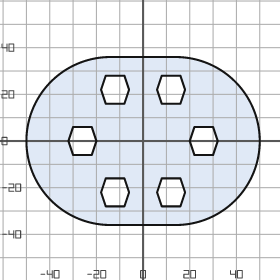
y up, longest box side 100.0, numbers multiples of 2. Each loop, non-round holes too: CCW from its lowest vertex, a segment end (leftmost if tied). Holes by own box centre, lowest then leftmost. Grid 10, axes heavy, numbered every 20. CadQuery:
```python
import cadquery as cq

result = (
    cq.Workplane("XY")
    .moveTo(-14.0, -36.0)
    .lineTo(14.0, -36.0)
    .threePointArc((50.0, 0.0), (14.0, 36.0))
    .lineTo(-14.0, 36.0)
    .threePointArc((-50.0, 0.0), (-14.0, -36.0))
    .close()
    .moveTo(-16.0, -28.0)
    .lineTo(-8.0, -28.0)
    .lineTo(-6.0, -22.0)
    .lineTo(-8.0, -16.0)
    .lineTo(-16.0, -16.0)
    .lineTo(-18.0, -22.0)
    .close()
    .moveTo(8.0, -28.0)
    .lineTo(16.0, -28.0)
    .lineTo(18.0, -22.0)
    .lineTo(16.0, -16.0)
    .lineTo(8.0, -16.0)
    .lineTo(6.0, -22.0)
    .close()
    .moveTo(-30.0, -6.0)
    .lineTo(-22.0, -6.0)
    .lineTo(-20.0, 0.0)
    .lineTo(-22.0, 6.0)
    .lineTo(-30.0, 6.0)
    .lineTo(-32.0, 0.0)
    .close()
    .moveTo(22.0, -6.0)
    .lineTo(30.0, -6.0)
    .lineTo(32.0, 0.0)
    .lineTo(30.0, 6.0)
    .lineTo(22.0, 6.0)
    .lineTo(20.0, 0.0)
    .close()
    .moveTo(-16.0, 16.0)
    .lineTo(-8.0, 16.0)
    .lineTo(-6.0, 22.0)
    .lineTo(-8.0, 28.0)
    .lineTo(-16.0, 28.0)
    .lineTo(-18.0, 22.0)
    .close()
    .moveTo(8.0, 16.0)
    .lineTo(16.0, 16.0)
    .lineTo(18.0, 22.0)
    .lineTo(16.0, 28.0)
    .lineTo(8.0, 28.0)
    .lineTo(6.0, 22.0)
    .close()
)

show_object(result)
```